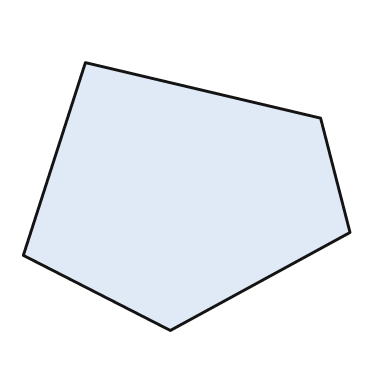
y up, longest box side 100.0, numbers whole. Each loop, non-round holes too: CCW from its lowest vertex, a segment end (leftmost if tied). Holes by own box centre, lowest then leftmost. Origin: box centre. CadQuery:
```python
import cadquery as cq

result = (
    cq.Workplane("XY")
    .moveTo(-5.0, -41.0)
    .lineTo(50.0, -11.0)
    .lineTo(41.0, 24.0)
    .lineTo(-31.0, 41.0)
    .lineTo(-50.0, -18.0)
    .close()
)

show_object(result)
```